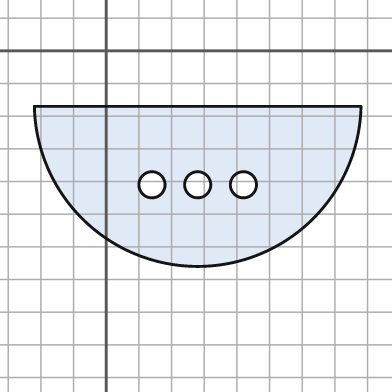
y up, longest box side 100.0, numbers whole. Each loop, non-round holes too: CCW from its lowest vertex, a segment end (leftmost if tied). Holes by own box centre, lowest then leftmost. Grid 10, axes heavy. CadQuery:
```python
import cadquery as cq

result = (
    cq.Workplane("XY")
    .moveTo(-22.0, -17.0)
    .threePointArc((28.0, -66.0), (78.0, -17.0))
    .close()
    .moveTo(14.0, -41.0)
    .circle(4.0)
    .moveTo(28.0, -41.0)
    .circle(4.0)
    .moveTo(42.0, -41.0)
    .circle(4.0)
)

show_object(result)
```